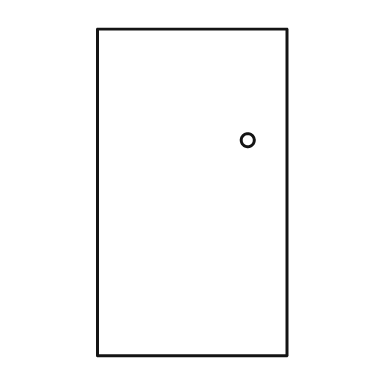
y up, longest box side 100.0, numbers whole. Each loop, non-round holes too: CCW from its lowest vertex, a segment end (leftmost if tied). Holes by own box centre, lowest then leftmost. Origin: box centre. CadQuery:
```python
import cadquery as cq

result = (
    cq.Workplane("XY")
    .moveTo(-29.0, -50.0)
    .lineTo(29.0, -50.0)
    .lineTo(29.0, 50.0)
    .lineTo(-29.0, 50.0)
    .close()
    .moveTo(17.0, 16.0)
    .circle(2.0)
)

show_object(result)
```